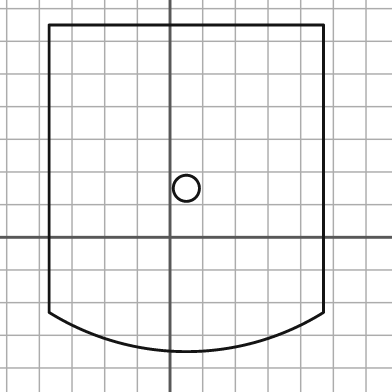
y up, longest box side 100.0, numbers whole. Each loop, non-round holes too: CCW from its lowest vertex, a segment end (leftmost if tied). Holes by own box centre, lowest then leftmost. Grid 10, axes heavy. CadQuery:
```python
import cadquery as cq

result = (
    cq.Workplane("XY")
    .moveTo(-37.0, -23.0)
    .threePointArc((5.0, -35.0), (47.0, -23.0))
    .lineTo(47.0, 65.0)
    .lineTo(-37.0, 65.0)
    .close()
    .moveTo(5.0, 15.0)
    .circle(4.0)
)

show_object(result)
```